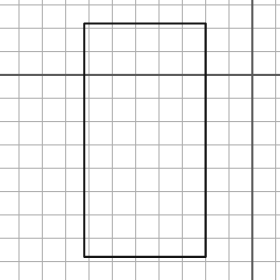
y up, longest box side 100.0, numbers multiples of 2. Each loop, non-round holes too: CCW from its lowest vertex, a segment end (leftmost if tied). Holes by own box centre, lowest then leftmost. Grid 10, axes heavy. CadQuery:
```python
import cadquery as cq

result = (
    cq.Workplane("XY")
    .moveTo(-72.0, -78.0)
    .lineTo(-20.0, -78.0)
    .lineTo(-20.0, 22.0)
    .lineTo(-72.0, 22.0)
    .close()
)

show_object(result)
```